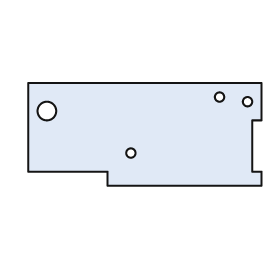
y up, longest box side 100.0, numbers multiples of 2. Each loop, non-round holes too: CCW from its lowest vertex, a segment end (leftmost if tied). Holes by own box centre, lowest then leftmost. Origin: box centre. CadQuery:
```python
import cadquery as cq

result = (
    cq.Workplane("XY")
    .moveTo(-16.0, -22.0)
    .lineTo(50.0, -22.0)
    .lineTo(50.0, -16.0)
    .lineTo(46.0, -16.0)
    .lineTo(46.0, 6.0)
    .lineTo(50.0, 6.0)
    .lineTo(50.0, 22.0)
    .lineTo(-50.0, 22.0)
    .lineTo(-50.0, -16.0)
    .lineTo(-16.0, -16.0)
    .close()
    .moveTo(-6.0, -8.0)
    .circle(2.0)
    .moveTo(-42.0, 10.0)
    .circle(4.0)
    .moveTo(44.0, 14.0)
    .circle(2.0)
    .moveTo(32.0, 16.0)
    .circle(2.0)
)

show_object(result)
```